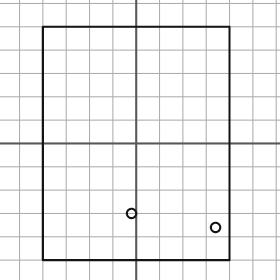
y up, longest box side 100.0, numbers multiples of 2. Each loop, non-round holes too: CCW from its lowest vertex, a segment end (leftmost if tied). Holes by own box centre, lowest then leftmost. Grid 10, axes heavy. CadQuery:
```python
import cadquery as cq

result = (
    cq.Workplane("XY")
    .moveTo(-40.0, -50.0)
    .lineTo(40.0, -50.0)
    .lineTo(40.0, 50.0)
    .lineTo(-40.0, 50.0)
    .close()
    .moveTo(34.0, -36.0)
    .circle(2.0)
    .moveTo(-2.0, -30.0)
    .circle(2.0)
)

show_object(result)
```